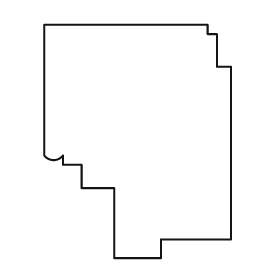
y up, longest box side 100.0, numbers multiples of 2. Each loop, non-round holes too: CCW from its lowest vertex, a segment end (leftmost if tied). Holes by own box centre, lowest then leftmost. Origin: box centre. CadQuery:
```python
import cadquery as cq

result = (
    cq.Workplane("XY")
    .moveTo(-10.0, -50.0)
    .lineTo(10.0, -50.0)
    .lineTo(10.0, -42.0)
    .lineTo(40.0, -42.0)
    .lineTo(40.0, 32.0)
    .lineTo(34.0, 32.0)
    .lineTo(34.0, 46.0)
    .lineTo(30.0, 46.0)
    .lineTo(30.0, 50.0)
    .lineTo(-40.0, 50.0)
    .lineTo(-40.0, -6.0)
    .threePointArc((-36.0, -8.0), (-32.0, -6.0))
    .lineTo(-32.0, -10.0)
    .lineTo(-24.0, -10.0)
    .lineTo(-24.0, -20.0)
    .lineTo(-10.0, -20.0)
    .close()
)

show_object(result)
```